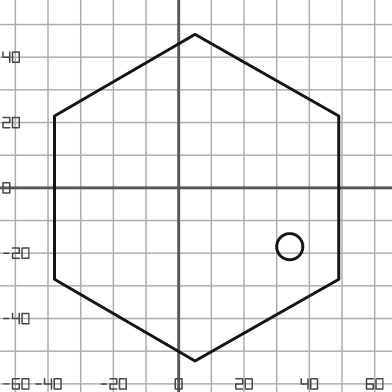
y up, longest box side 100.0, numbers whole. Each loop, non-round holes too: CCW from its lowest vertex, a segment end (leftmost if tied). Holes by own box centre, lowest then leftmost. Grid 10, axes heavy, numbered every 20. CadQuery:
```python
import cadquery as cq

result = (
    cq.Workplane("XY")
    .moveTo(5.0, -53.0)
    .lineTo(49.0, -28.0)
    .lineTo(49.0, 22.0)
    .lineTo(5.0, 47.0)
    .lineTo(-38.0, 22.0)
    .lineTo(-38.0, -28.0)
    .close()
    .moveTo(34.0, -18.0)
    .circle(4.0)
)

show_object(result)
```